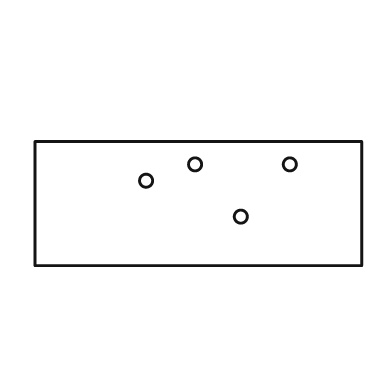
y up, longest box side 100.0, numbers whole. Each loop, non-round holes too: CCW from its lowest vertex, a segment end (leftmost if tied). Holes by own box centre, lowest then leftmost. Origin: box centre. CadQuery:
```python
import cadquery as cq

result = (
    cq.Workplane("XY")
    .moveTo(-50.0, -19.0)
    .lineTo(50.0, -19.0)
    .lineTo(50.0, 19.0)
    .lineTo(-50.0, 19.0)
    .close()
    .moveTo(13.0, -4.0)
    .circle(2.0)
    .moveTo(-16.0, 7.0)
    .circle(2.0)
    .moveTo(-1.0, 12.0)
    .circle(2.0)
    .moveTo(28.0, 12.0)
    .circle(2.0)
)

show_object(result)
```